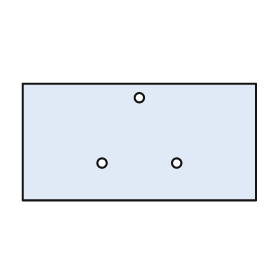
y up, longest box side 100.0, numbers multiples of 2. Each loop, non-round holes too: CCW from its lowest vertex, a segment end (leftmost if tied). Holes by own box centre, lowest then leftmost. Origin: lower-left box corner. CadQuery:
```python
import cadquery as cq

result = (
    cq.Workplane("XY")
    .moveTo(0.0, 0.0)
    .lineTo(100.0, 0.0)
    .lineTo(100.0, 50.0)
    .lineTo(0.0, 50.0)
    .close()
    .moveTo(34.0, 16.0)
    .circle(2.0)
    .moveTo(66.0, 16.0)
    .circle(2.0)
    .moveTo(50.0, 44.0)
    .circle(2.0)
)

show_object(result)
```